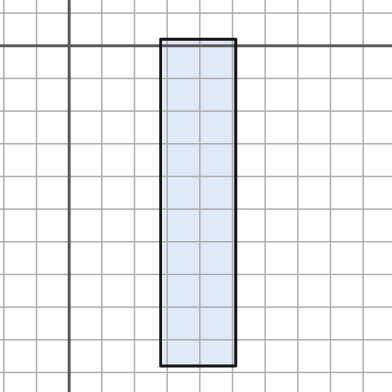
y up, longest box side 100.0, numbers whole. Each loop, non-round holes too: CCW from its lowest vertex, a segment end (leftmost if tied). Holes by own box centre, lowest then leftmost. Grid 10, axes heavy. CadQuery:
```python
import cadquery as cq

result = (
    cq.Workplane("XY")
    .moveTo(28.0, -98.0)
    .lineTo(51.0, -98.0)
    .lineTo(51.0, 2.0)
    .lineTo(28.0, 2.0)
    .close()
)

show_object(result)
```